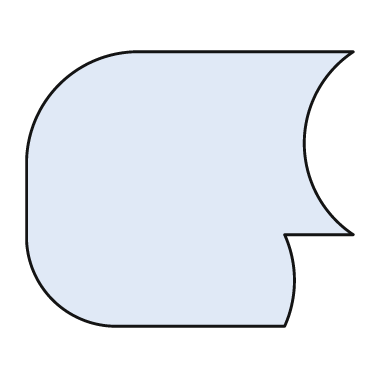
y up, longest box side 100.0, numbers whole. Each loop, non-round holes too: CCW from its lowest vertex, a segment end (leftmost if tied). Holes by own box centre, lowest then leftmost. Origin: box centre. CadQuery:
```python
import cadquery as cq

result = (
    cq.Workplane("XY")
    .moveTo(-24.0, -42.0)
    .lineTo(29.0, -42.0)
    .threePointArc((32.0, -28.0), (29.0, -14.0))
    .lineTo(50.0, -14.0)
    .threePointArc((35.0, 14.0), (50.0, 42.0))
    .lineTo(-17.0, 42.0)
    .threePointArc((-40.0, 32.0), (-50.0, 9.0))
    .lineTo(-50.0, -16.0)
    .threePointArc((-42.0, -34.0), (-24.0, -42.0))
    .close()
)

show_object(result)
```